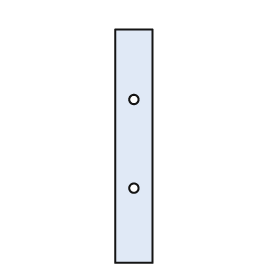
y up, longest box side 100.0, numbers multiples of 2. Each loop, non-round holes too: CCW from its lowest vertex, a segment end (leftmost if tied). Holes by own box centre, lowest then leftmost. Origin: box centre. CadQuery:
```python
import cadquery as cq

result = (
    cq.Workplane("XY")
    .moveTo(-8.0, -50.0)
    .lineTo(8.0, -50.0)
    .lineTo(8.0, 50.0)
    .lineTo(-8.0, 50.0)
    .close()
    .moveTo(0.0, -18.0)
    .circle(2.0)
    .moveTo(0.0, 20.0)
    .circle(2.0)
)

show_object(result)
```